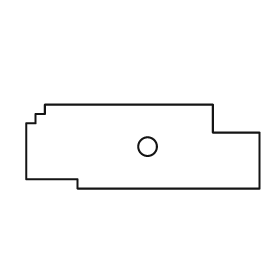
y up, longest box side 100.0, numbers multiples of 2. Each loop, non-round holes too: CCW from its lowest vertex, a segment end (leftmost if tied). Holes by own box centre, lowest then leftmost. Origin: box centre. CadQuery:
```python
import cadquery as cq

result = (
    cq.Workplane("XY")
    .moveTo(-28.0, -18.0)
    .lineTo(50.0, -18.0)
    .lineTo(50.0, 6.0)
    .lineTo(30.0, 6.0)
    .lineTo(30.0, 18.0)
    .lineTo(-42.0, 18.0)
    .lineTo(-42.0, 14.0)
    .lineTo(-46.0, 14.0)
    .lineTo(-46.0, 10.0)
    .lineTo(-50.0, 10.0)
    .lineTo(-50.0, -14.0)
    .lineTo(-28.0, -14.0)
    .close()
    .moveTo(2.0, 0.0)
    .circle(4.0)
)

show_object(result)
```